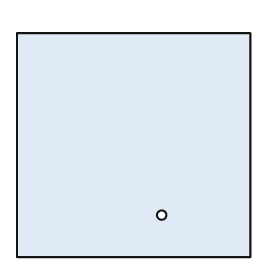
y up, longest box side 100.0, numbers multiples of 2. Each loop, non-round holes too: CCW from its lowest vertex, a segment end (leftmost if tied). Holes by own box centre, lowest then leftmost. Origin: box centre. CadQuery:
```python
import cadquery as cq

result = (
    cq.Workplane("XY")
    .moveTo(-50.0, -48.0)
    .lineTo(50.0, -48.0)
    .lineTo(50.0, 48.0)
    .lineTo(-50.0, 48.0)
    .close()
    .moveTo(12.0, -30.0)
    .circle(2.0)
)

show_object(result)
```